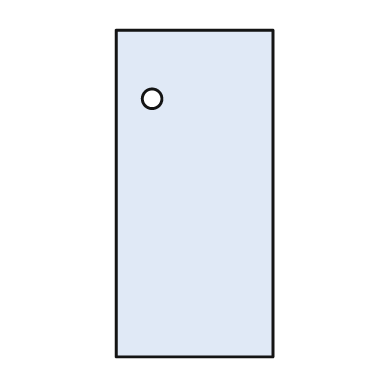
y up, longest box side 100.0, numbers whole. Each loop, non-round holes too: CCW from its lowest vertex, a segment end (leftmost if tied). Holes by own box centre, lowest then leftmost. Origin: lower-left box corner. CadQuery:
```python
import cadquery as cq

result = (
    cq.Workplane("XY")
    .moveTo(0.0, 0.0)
    .lineTo(48.0, 0.0)
    .lineTo(48.0, 100.0)
    .lineTo(0.0, 100.0)
    .close()
    .moveTo(11.0, 79.0)
    .circle(3.0)
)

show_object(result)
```